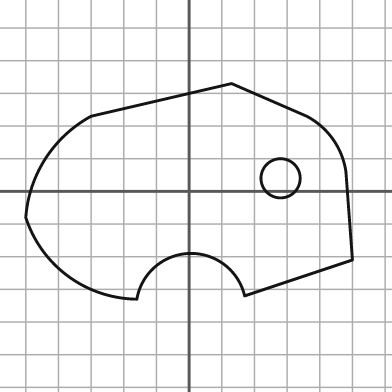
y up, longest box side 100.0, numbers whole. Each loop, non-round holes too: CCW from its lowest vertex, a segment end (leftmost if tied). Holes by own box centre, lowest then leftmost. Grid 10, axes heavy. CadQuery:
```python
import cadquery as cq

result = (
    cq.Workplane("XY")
    .moveTo(-16.0, -33.0)
    .threePointArc((0.0, -19.0), (17.0, -32.0))
    .lineTo(50.0, -21.0)
    .lineTo(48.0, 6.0)
    .threePointArc((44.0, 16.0), (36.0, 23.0))
    .lineTo(13.0, 33.0)
    .lineTo(-30.0, 23.0)
    .threePointArc((-44.0, 10.0), (-50.0, -8.0))
    .threePointArc((-37.0, -26.0), (-16.0, -33.0))
    .close()
    .moveTo(28.0, 4.0)
    .circle(6.0)
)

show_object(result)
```